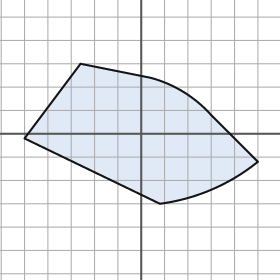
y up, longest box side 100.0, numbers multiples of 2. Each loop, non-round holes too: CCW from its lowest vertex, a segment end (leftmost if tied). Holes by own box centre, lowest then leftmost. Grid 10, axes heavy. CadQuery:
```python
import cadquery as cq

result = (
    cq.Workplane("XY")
    .moveTo(8.0, -30.0)
    .threePointArc((30.0, -24.0), (50.0, -12.0))
    .lineTo(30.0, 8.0)
    .threePointArc((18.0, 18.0), (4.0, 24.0))
    .lineTo(-26.0, 30.0)
    .lineTo(-50.0, -2.0)
    .close()
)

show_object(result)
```